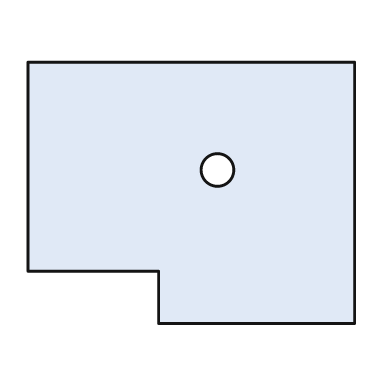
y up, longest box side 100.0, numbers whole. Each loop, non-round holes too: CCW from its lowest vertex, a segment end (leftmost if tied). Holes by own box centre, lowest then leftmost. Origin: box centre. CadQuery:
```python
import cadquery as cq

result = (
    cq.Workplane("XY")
    .moveTo(-10.0, -40.0)
    .lineTo(50.0, -40.0)
    .lineTo(50.0, 40.0)
    .lineTo(-50.0, 40.0)
    .lineTo(-50.0, -24.0)
    .lineTo(-10.0, -24.0)
    .close()
    .moveTo(8.0, 7.0)
    .circle(5.0)
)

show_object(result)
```